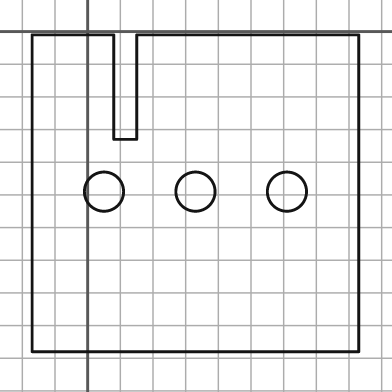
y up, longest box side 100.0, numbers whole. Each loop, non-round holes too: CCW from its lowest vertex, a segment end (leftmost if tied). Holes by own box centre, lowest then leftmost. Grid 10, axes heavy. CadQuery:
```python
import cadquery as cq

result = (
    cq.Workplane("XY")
    .moveTo(-17.0, -98.0)
    .lineTo(83.0, -98.0)
    .lineTo(83.0, -1.0)
    .lineTo(15.0, -1.0)
    .lineTo(15.0, -33.0)
    .lineTo(8.0, -33.0)
    .lineTo(8.0, -1.0)
    .lineTo(-17.0, -1.0)
    .close()
    .moveTo(5.0, -49.0)
    .circle(6.0)
    .moveTo(33.0, -49.0)
    .circle(6.0)
    .moveTo(61.0, -49.0)
    .circle(6.0)
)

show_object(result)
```